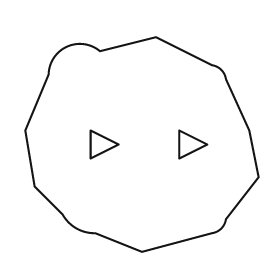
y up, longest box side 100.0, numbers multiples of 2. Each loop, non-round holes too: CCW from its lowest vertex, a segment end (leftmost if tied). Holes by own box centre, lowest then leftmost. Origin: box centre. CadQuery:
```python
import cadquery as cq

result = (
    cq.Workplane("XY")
    .moveTo(0.0, -46.0)
    .lineTo(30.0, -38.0)
    .threePointArc((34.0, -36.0), (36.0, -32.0))
    .lineTo(50.0, -14.0)
    .lineTo(46.0, 6.0)
    .lineTo(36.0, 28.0)
    .threePointArc((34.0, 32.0), (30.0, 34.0))
    .lineTo(6.0, 46.0)
    .lineTo(-18.0, 40.0)
    .threePointArc((-32.0, 42.0), (-40.0, 30.0))
    .lineTo(-50.0, 6.0)
    .lineTo(-46.0, -18.0)
    .lineTo(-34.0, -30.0)
    .threePointArc((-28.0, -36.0), (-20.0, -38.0))
    .close()
    .moveTo(-22.0, -6.0)
    .lineTo(-10.0, 0.0)
    .lineTo(-22.0, 6.0)
    .close()
    .moveTo(16.0, -6.0)
    .lineTo(28.0, 0.0)
    .lineTo(16.0, 6.0)
    .close()
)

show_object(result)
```